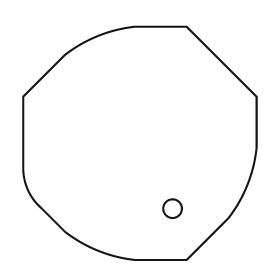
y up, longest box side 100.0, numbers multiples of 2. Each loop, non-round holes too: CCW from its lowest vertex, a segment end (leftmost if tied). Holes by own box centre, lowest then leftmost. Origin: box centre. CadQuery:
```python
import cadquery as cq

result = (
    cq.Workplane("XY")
    .moveTo(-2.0, -50.0)
    .lineTo(20.0, -50.0)
    .lineTo(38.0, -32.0)
    .threePointArc((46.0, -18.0), (50.0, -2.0))
    .lineTo(50.0, 20.0)
    .lineTo(20.0, 50.0)
    .lineTo(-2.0, 50.0)
    .threePointArc((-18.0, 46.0), (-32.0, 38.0))
    .lineTo(-50.0, 20.0)
    .lineTo(-50.0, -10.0)
    .threePointArc((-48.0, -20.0), (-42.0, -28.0))
    .lineTo(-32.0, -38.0)
    .threePointArc((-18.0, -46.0), (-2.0, -50.0))
    .close()
    .moveTo(14.0, -28.0)
    .circle(4.0)
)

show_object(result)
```